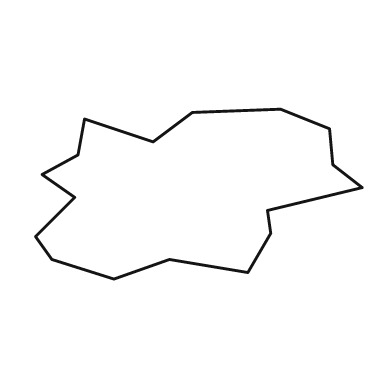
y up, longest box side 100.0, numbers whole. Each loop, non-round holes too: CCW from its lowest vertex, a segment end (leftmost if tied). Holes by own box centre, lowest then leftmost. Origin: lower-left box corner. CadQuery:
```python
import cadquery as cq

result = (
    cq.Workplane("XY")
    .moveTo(24.0, 0.0)
    .lineTo(41.0, 6.0)
    .lineTo(65.0, 2.0)
    .lineTo(72.0, 14.0)
    .lineTo(71.0, 21.0)
    .lineTo(100.0, 28.0)
    .lineTo(91.0, 35.0)
    .lineTo(90.0, 46.0)
    .lineTo(75.0, 52.0)
    .lineTo(48.0, 51.0)
    .lineTo(36.0, 42.0)
    .lineTo(15.0, 49.0)
    .lineTo(13.0, 38.0)
    .lineTo(2.0, 32.0)
    .lineTo(12.0, 25.0)
    .lineTo(0.0, 13.0)
    .lineTo(5.0, 6.0)
    .close()
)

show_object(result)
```